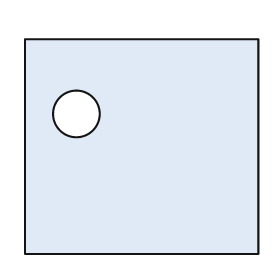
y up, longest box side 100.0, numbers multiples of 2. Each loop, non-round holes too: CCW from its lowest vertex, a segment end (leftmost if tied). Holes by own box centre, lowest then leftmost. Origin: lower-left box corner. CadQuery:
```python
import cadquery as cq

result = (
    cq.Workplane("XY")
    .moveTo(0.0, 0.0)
    .lineTo(100.0, 0.0)
    .lineTo(100.0, 92.0)
    .lineTo(0.0, 92.0)
    .close()
    .moveTo(22.0, 60.0)
    .circle(10.0)
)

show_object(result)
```